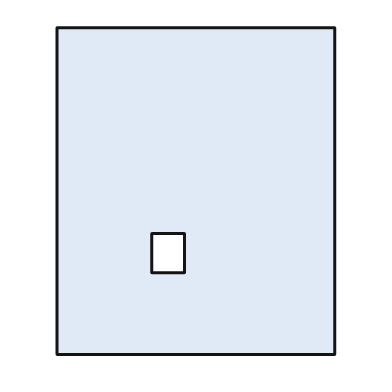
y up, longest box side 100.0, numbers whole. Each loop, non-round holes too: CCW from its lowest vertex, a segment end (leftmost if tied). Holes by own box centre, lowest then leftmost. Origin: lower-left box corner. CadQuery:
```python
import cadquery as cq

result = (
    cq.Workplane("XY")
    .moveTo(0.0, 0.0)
    .lineTo(85.0, 0.0)
    .lineTo(85.0, 100.0)
    .lineTo(0.0, 100.0)
    .close()
    .moveTo(29.0, 25.0)
    .lineTo(39.0, 25.0)
    .lineTo(39.0, 37.0)
    .lineTo(29.0, 37.0)
    .close()
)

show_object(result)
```